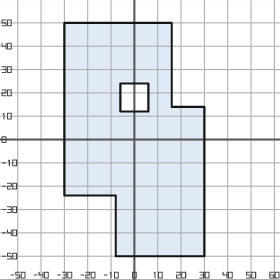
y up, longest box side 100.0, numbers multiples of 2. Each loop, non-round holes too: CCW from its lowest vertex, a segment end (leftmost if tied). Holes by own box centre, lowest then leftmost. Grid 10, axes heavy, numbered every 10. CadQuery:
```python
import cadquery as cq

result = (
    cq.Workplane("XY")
    .moveTo(-8.0, -50.0)
    .lineTo(30.0, -50.0)
    .lineTo(30.0, 14.0)
    .lineTo(16.0, 14.0)
    .lineTo(16.0, 50.0)
    .lineTo(-30.0, 50.0)
    .lineTo(-30.0, -24.0)
    .lineTo(-8.0, -24.0)
    .close()
    .moveTo(-6.0, 12.0)
    .lineTo(6.0, 12.0)
    .lineTo(6.0, 24.0)
    .lineTo(-6.0, 24.0)
    .close()
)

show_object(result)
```